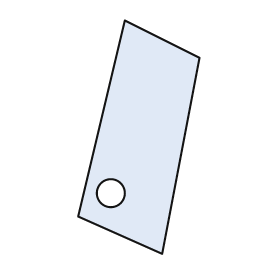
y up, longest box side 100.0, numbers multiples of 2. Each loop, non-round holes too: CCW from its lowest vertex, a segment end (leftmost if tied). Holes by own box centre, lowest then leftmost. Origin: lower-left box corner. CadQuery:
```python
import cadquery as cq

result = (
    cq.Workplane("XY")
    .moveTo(36.0, 0.0)
    .lineTo(52.0, 84.0)
    .lineTo(20.0, 100.0)
    .lineTo(0.0, 16.0)
    .close()
    .moveTo(14.0, 26.0)
    .circle(6.0)
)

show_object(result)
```